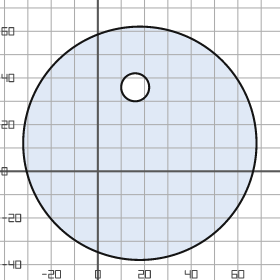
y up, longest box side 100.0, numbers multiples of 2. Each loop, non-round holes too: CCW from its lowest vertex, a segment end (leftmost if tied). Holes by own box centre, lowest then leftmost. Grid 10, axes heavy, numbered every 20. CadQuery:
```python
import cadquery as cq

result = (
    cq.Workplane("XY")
    .moveTo(18.0, 12.0)
    .circle(50.0)
    .moveTo(16.0, 36.0)
    .circle(6.0)
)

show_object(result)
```